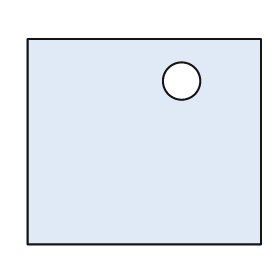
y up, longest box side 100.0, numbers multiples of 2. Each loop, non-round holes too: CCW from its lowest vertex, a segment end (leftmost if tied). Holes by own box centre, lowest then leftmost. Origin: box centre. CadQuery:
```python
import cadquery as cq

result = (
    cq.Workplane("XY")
    .moveTo(-50.0, -44.0)
    .lineTo(50.0, -44.0)
    .lineTo(50.0, 44.0)
    .lineTo(-50.0, 44.0)
    .close()
    .moveTo(16.0, 26.0)
    .circle(8.0)
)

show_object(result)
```